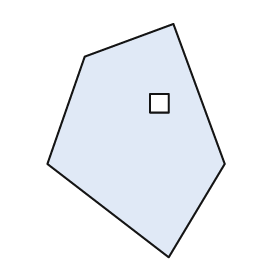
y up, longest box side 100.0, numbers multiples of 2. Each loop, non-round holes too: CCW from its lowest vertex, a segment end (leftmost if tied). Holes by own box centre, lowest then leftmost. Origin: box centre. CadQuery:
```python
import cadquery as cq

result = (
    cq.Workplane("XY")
    .moveTo(14.0, -50.0)
    .lineTo(38.0, -10.0)
    .lineTo(16.0, 50.0)
    .lineTo(-22.0, 36.0)
    .lineTo(-38.0, -10.0)
    .close()
    .moveTo(6.0, 12.0)
    .lineTo(14.0, 12.0)
    .lineTo(14.0, 20.0)
    .lineTo(6.0, 20.0)
    .close()
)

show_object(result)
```